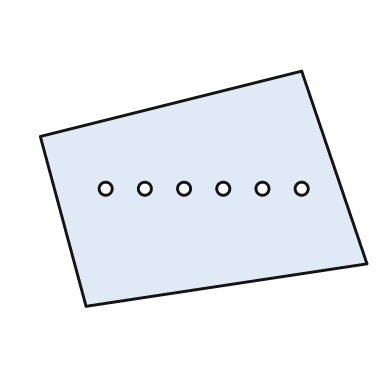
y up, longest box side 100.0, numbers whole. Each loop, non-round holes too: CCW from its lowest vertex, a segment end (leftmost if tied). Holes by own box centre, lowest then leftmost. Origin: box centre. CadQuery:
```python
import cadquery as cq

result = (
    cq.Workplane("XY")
    .moveTo(-36.0, -36.0)
    .lineTo(50.0, -23.0)
    .lineTo(30.0, 36.0)
    .lineTo(-50.0, 16.0)
    .close()
    .moveTo(-30.0, 0.0)
    .circle(2.0)
    .moveTo(-18.0, 0.0)
    .circle(2.0)
    .moveTo(-6.0, 0.0)
    .circle(2.0)
    .moveTo(6.0, 0.0)
    .circle(2.0)
    .moveTo(18.0, 0.0)
    .circle(2.0)
    .moveTo(30.0, 0.0)
    .circle(2.0)
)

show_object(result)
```